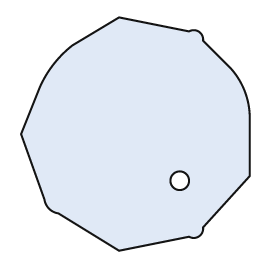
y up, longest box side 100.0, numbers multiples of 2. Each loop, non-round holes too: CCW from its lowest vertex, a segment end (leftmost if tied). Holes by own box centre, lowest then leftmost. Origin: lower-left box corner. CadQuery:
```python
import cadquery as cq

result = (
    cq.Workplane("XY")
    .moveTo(42.0, 0.0)
    .lineTo(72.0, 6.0)
    .threePointArc((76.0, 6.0), (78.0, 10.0))
    .lineTo(98.0, 32.0)
    .lineTo(98.0, 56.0)
    .threePointArc((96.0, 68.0), (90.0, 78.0))
    .lineTo(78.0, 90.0)
    .threePointArc((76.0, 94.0), (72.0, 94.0))
    .lineTo(42.0, 100.0)
    .lineTo(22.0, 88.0)
    .threePointArc((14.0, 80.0), (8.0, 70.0))
    .lineTo(0.0, 50.0)
    .lineTo(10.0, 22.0)
    .threePointArc((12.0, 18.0), (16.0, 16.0))
    .close()
    .moveTo(68.0, 30.0)
    .circle(4.0)
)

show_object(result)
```